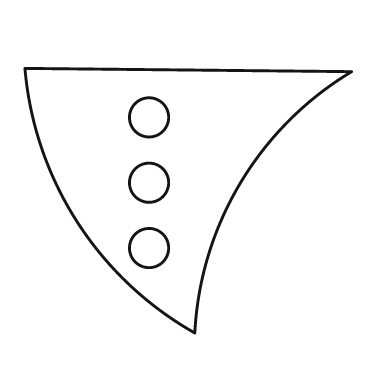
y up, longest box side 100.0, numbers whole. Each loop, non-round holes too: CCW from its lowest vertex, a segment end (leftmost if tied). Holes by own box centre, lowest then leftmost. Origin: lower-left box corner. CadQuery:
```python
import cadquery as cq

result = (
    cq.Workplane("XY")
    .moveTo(52.0, 0.0)
    .threePointArc((66.0, 46.0), (100.0, 80.0))
    .lineTo(0.0, 81.0)
    .threePointArc((16.0, 34.0), (52.0, 0.0))
    .close()
    .moveTo(38.0, 26.0)
    .circle(6.0)
    .moveTo(38.0, 46.0)
    .circle(6.0)
    .moveTo(38.0, 66.0)
    .circle(6.0)
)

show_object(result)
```